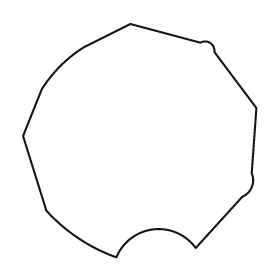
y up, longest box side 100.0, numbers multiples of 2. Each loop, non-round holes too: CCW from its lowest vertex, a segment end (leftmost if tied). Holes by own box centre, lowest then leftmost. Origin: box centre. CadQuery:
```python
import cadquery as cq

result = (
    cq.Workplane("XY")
    .moveTo(-10.0, -50.0)
    .threePointArc((6.0, -38.0), (24.0, -46.0))
    .lineTo(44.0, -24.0)
    .threePointArc((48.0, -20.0), (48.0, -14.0))
    .lineTo(50.0, 14.0)
    .lineTo(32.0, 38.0)
    .threePointArc((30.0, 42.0), (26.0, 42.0))
    .lineTo(-4.0, 50.0)
    .lineTo(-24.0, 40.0)
    .threePointArc((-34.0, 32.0), (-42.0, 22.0))
    .lineTo(-50.0, 2.0)
    .lineTo(-40.0, -30.0)
    .threePointArc((-26.0, -42.0), (-10.0, -50.0))
    .close()
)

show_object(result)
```